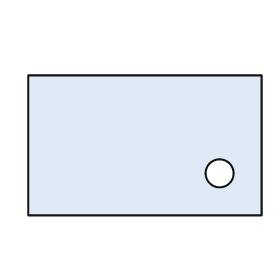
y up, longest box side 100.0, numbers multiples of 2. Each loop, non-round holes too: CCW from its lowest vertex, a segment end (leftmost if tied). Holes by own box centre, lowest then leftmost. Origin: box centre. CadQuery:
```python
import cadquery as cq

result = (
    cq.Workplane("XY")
    .moveTo(-50.0, -30.0)
    .lineTo(50.0, -30.0)
    .lineTo(50.0, 30.0)
    .lineTo(-50.0, 30.0)
    .close()
    .moveTo(32.0, -12.0)
    .circle(6.0)
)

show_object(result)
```